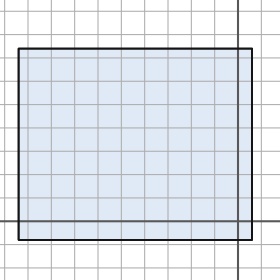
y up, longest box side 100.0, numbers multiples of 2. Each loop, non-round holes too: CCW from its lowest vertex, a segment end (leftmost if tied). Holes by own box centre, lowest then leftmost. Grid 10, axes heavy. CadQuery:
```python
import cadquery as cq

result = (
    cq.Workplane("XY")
    .moveTo(-94.0, -8.0)
    .lineTo(6.0, -8.0)
    .lineTo(6.0, 74.0)
    .lineTo(-94.0, 74.0)
    .close()
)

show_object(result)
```